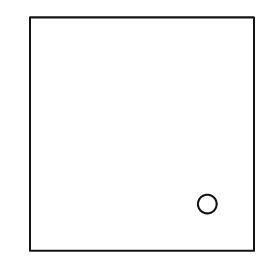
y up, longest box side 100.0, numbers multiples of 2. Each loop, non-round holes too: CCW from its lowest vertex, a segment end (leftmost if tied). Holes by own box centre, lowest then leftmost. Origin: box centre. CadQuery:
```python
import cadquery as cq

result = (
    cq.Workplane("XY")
    .moveTo(-48.0, -50.0)
    .lineTo(48.0, -50.0)
    .lineTo(48.0, 50.0)
    .lineTo(-48.0, 50.0)
    .close()
    .moveTo(28.0, -30.0)
    .circle(4.0)
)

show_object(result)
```